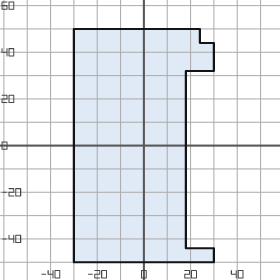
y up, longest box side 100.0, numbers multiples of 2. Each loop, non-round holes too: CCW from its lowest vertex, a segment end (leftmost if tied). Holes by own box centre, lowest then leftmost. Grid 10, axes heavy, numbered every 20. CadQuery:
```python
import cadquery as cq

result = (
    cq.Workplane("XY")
    .moveTo(-30.0, -50.0)
    .lineTo(30.0, -50.0)
    .lineTo(30.0, -44.0)
    .lineTo(18.0, -44.0)
    .lineTo(18.0, 32.0)
    .lineTo(30.0, 32.0)
    .lineTo(30.0, 44.0)
    .lineTo(24.0, 44.0)
    .lineTo(24.0, 50.0)
    .lineTo(-30.0, 50.0)
    .close()
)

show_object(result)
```